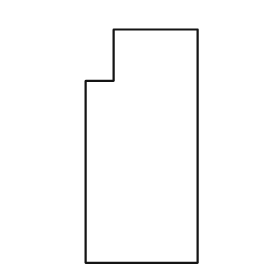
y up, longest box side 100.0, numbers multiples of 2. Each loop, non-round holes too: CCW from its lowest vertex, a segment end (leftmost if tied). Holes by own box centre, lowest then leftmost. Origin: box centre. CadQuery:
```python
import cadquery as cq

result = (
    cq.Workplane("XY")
    .moveTo(-24.0, -50.0)
    .lineTo(24.0, -50.0)
    .lineTo(24.0, 50.0)
    .lineTo(-12.0, 50.0)
    .lineTo(-12.0, 28.0)
    .lineTo(-24.0, 28.0)
    .close()
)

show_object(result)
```